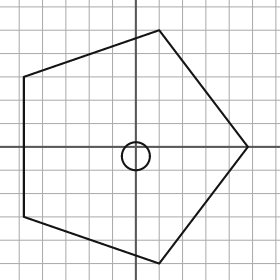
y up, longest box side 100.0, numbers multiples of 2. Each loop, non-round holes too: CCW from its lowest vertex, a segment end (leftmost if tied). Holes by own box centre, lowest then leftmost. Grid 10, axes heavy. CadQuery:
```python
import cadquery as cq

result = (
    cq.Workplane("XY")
    .moveTo(10.0, -50.0)
    .lineTo(48.0, 0.0)
    .lineTo(10.0, 50.0)
    .lineTo(-48.0, 30.0)
    .lineTo(-48.0, -30.0)
    .close()
    .moveTo(0.0, -4.0)
    .circle(6.0)
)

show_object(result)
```